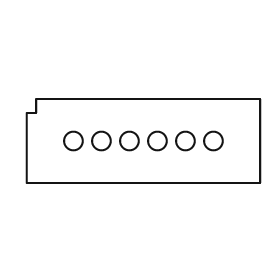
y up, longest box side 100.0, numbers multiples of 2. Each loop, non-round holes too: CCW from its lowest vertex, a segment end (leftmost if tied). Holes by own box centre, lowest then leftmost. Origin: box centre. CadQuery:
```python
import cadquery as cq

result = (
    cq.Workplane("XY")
    .moveTo(-50.0, -18.0)
    .lineTo(50.0, -18.0)
    .lineTo(50.0, 18.0)
    .lineTo(-46.0, 18.0)
    .lineTo(-46.0, 12.0)
    .lineTo(-50.0, 12.0)
    .close()
    .moveTo(-30.0, 0.0)
    .circle(4.0)
    .moveTo(-18.0, 0.0)
    .circle(4.0)
    .moveTo(-6.0, 0.0)
    .circle(4.0)
    .moveTo(6.0, 0.0)
    .circle(4.0)
    .moveTo(18.0, 0.0)
    .circle(4.0)
    .moveTo(30.0, 0.0)
    .circle(4.0)
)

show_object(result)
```